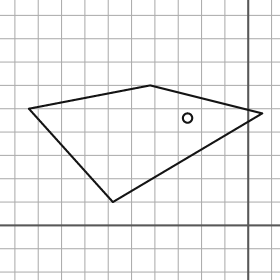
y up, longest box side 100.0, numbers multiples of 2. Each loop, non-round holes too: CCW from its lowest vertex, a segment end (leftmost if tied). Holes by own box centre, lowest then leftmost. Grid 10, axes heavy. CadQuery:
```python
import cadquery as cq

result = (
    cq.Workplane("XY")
    .moveTo(-58.0, 10.0)
    .lineTo(6.0, 48.0)
    .lineTo(-42.0, 60.0)
    .lineTo(-94.0, 50.0)
    .close()
    .moveTo(-26.0, 46.0)
    .circle(2.0)
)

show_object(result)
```